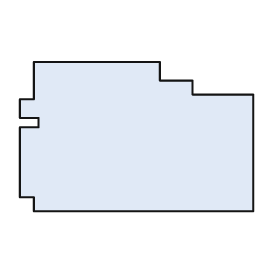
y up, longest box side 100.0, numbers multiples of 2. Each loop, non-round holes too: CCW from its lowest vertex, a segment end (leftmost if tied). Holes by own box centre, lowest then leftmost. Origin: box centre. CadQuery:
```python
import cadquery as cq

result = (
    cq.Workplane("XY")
    .moveTo(-44.0, -32.0)
    .lineTo(50.0, -32.0)
    .lineTo(50.0, 18.0)
    .lineTo(24.0, 18.0)
    .lineTo(24.0, 24.0)
    .lineTo(10.0, 24.0)
    .lineTo(10.0, 32.0)
    .lineTo(-44.0, 32.0)
    .lineTo(-44.0, 16.0)
    .lineTo(-50.0, 16.0)
    .lineTo(-50.0, 8.0)
    .lineTo(-42.0, 8.0)
    .lineTo(-42.0, 4.0)
    .lineTo(-50.0, 4.0)
    .lineTo(-50.0, -26.0)
    .lineTo(-44.0, -26.0)
    .close()
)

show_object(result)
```